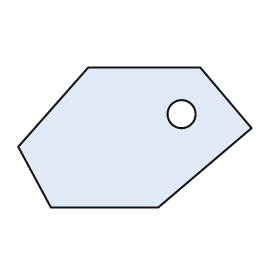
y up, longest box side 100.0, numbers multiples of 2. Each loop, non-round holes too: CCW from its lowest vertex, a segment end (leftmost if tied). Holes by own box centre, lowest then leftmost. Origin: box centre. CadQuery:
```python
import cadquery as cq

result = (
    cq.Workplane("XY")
    .moveTo(-36.0, -30.0)
    .lineTo(10.0, -30.0)
    .lineTo(50.0, 4.0)
    .lineTo(28.0, 30.0)
    .lineTo(-20.0, 30.0)
    .lineTo(-50.0, -4.0)
    .close()
    .moveTo(20.0, 10.0)
    .circle(6.0)
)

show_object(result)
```